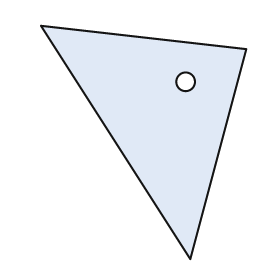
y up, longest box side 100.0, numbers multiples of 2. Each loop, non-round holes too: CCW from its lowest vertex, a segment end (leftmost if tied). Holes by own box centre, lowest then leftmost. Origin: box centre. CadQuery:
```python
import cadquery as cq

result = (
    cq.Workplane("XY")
    .moveTo(20.0, -50.0)
    .lineTo(44.0, 40.0)
    .lineTo(-44.0, 50.0)
    .close()
    .moveTo(18.0, 26.0)
    .circle(4.0)
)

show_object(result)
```